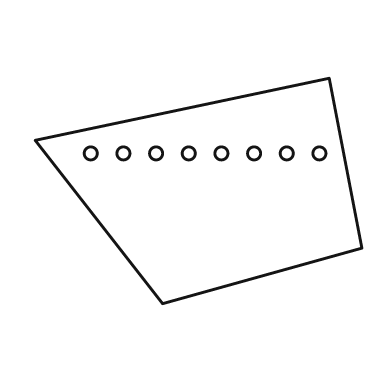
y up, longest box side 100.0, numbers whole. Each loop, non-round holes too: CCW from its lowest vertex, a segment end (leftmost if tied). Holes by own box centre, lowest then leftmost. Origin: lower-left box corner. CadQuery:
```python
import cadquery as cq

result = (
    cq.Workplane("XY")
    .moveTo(39.0, 0.0)
    .lineTo(100.0, 17.0)
    .lineTo(90.0, 69.0)
    .lineTo(0.0, 50.0)
    .close()
    .moveTo(17.0, 46.0)
    .circle(2.0)
    .moveTo(27.0, 46.0)
    .circle(2.0)
    .moveTo(37.0, 46.0)
    .circle(2.0)
    .moveTo(47.0, 46.0)
    .circle(2.0)
    .moveTo(57.0, 46.0)
    .circle(2.0)
    .moveTo(67.0, 46.0)
    .circle(2.0)
    .moveTo(77.0, 46.0)
    .circle(2.0)
    .moveTo(87.0, 46.0)
    .circle(2.0)
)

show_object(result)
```